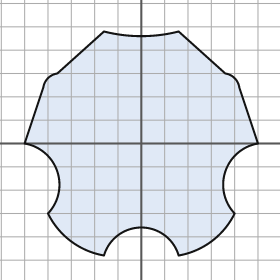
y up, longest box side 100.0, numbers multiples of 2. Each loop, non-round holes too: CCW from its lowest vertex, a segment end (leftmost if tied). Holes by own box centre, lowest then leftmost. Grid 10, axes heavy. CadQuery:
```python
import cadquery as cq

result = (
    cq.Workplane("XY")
    .moveTo(-16.0, -48.0)
    .threePointArc((0.0, -36.0), (16.0, -48.0))
    .threePointArc((30.0, -42.0), (40.0, -30.0))
    .threePointArc((36.0, -12.0), (50.0, 0.0))
    .lineTo(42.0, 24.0)
    .threePointArc((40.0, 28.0), (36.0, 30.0))
    .lineTo(16.0, 48.0)
    .threePointArc((0.0, 46.0), (-16.0, 48.0))
    .lineTo(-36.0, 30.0)
    .threePointArc((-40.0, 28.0), (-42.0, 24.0))
    .lineTo(-50.0, 0.0)
    .threePointArc((-36.0, -12.0), (-40.0, -30.0))
    .threePointArc((-30.0, -42.0), (-16.0, -48.0))
    .close()
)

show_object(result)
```